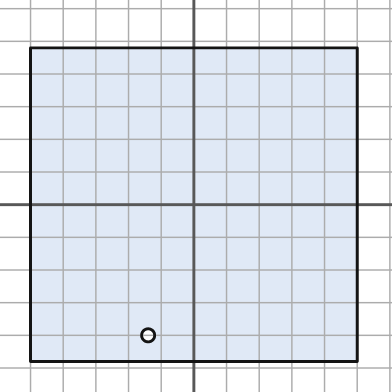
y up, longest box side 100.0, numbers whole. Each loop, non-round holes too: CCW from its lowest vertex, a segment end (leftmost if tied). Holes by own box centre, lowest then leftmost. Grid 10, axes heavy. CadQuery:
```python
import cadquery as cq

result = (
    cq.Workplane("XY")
    .moveTo(-50.0, -48.0)
    .lineTo(50.0, -48.0)
    .lineTo(50.0, 48.0)
    .lineTo(-50.0, 48.0)
    .close()
    .moveTo(-14.0, -40.0)
    .circle(2.0)
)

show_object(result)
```